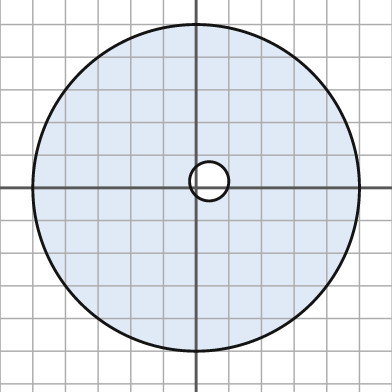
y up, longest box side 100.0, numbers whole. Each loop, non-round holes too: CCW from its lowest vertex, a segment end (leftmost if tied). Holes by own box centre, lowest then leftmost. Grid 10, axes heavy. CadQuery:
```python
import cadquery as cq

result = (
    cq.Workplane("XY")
    .moveTo(0.0, 0.0)
    .circle(50.0)
    .moveTo(4.0, 2.0)
    .circle(6.0)
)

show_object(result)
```